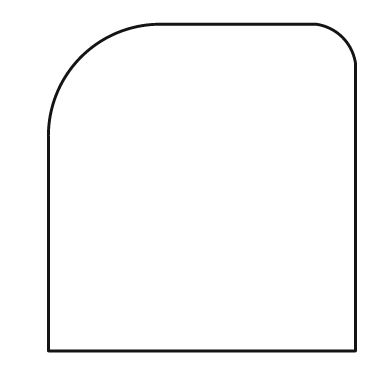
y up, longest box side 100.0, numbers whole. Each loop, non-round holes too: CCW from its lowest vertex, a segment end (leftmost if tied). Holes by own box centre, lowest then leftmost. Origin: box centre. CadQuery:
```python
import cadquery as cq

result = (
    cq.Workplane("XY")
    .moveTo(-47.0, -50.0)
    .lineTo(47.0, -50.0)
    .lineTo(47.0, 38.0)
    .threePointArc((43.0, 46.0), (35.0, 50.0))
    .lineTo(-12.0, 50.0)
    .threePointArc((-37.0, 40.0), (-47.0, 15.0))
    .close()
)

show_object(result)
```